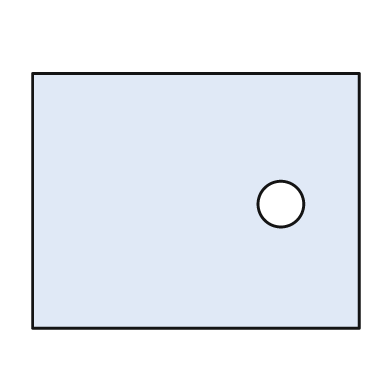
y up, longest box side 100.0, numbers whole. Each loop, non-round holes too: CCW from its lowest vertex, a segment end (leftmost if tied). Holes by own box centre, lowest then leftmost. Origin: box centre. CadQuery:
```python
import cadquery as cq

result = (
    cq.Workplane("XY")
    .moveTo(-50.0, -39.0)
    .lineTo(50.0, -39.0)
    .lineTo(50.0, 39.0)
    .lineTo(-50.0, 39.0)
    .close()
    .moveTo(26.0, -1.0)
    .circle(7.0)
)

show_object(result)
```